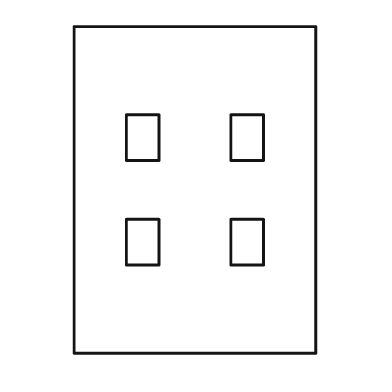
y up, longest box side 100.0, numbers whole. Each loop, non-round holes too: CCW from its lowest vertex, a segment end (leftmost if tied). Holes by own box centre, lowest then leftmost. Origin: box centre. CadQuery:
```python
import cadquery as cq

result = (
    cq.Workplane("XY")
    .moveTo(-37.0, -50.0)
    .lineTo(37.0, -50.0)
    .lineTo(37.0, 50.0)
    .lineTo(-37.0, 50.0)
    .close()
    .moveTo(-21.0, -23.0)
    .lineTo(-11.0, -23.0)
    .lineTo(-11.0, -9.0)
    .lineTo(-21.0, -9.0)
    .close()
    .moveTo(11.0, -23.0)
    .lineTo(21.0, -23.0)
    .lineTo(21.0, -9.0)
    .lineTo(11.0, -9.0)
    .close()
    .moveTo(-21.0, 9.0)
    .lineTo(-11.0, 9.0)
    .lineTo(-11.0, 23.0)
    .lineTo(-21.0, 23.0)
    .close()
    .moveTo(11.0, 9.0)
    .lineTo(21.0, 9.0)
    .lineTo(21.0, 23.0)
    .lineTo(11.0, 23.0)
    .close()
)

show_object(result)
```